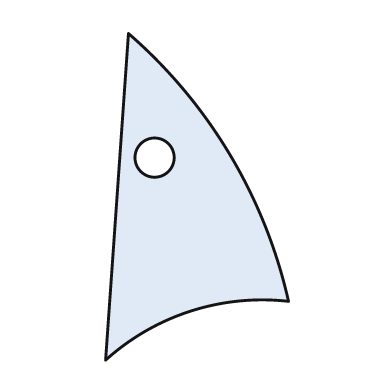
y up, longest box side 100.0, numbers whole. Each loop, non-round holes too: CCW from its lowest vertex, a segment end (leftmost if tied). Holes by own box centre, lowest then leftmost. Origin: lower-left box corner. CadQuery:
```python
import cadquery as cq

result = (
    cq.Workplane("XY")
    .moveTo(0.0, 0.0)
    .threePointArc((26.0, 15.0), (56.0, 18.0))
    .threePointArc((38.0, 63.0), (7.0, 100.0))
    .close()
    .moveTo(15.0, 62.0)
    .circle(6.0)
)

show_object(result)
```